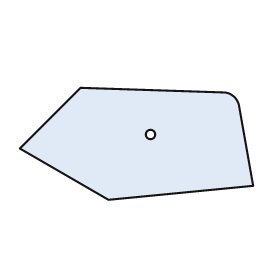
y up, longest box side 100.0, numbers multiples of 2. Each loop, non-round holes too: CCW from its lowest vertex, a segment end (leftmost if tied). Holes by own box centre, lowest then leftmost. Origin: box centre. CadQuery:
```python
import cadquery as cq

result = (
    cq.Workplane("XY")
    .moveTo(-12.0, -24.0)
    .lineTo(50.0, -18.0)
    .lineTo(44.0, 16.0)
    .threePointArc((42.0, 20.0), (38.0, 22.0))
    .lineTo(-24.0, 24.0)
    .lineTo(-50.0, -2.0)
    .close()
    .moveTo(6.0, 4.0)
    .circle(2.0)
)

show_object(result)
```